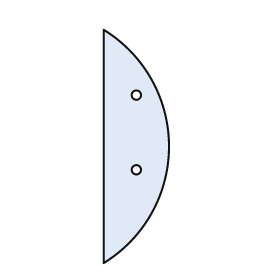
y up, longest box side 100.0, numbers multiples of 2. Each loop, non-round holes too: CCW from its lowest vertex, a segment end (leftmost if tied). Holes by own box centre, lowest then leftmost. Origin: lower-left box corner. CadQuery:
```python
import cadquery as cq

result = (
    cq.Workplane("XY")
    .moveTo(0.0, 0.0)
    .threePointArc((28.0, 50.0), (0.0, 100.0))
    .close()
    .moveTo(14.0, 40.0)
    .circle(2.0)
    .moveTo(14.0, 72.0)
    .circle(2.0)
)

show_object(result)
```